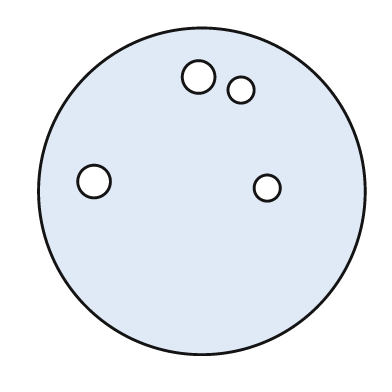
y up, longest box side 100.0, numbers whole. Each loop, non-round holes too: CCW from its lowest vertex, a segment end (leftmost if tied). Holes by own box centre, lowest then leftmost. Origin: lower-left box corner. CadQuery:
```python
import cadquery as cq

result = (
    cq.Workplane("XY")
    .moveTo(50.0, 50.0)
    .circle(50.0)
    .moveTo(70.0, 51.0)
    .circle(4.0)
    .moveTo(17.0, 53.0)
    .circle(5.0)
    .moveTo(62.0, 81.0)
    .circle(4.0)
    .moveTo(49.0, 85.0)
    .circle(5.0)
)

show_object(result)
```